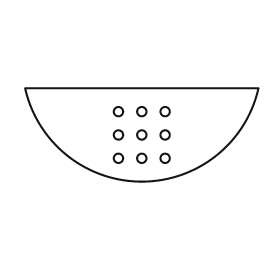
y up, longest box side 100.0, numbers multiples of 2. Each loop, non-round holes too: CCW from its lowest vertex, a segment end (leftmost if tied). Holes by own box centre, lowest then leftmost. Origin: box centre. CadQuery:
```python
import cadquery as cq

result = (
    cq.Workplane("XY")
    .moveTo(-50.0, 20.0)
    .threePointArc((0.0, -20.0), (50.0, 20.0))
    .close()
    .moveTo(-10.0, -10.0)
    .circle(2.0)
    .moveTo(0.0, -10.0)
    .circle(2.0)
    .moveTo(10.0, -10.0)
    .circle(2.0)
    .moveTo(-10.0, 0.0)
    .circle(2.0)
    .moveTo(0.0, 0.0)
    .circle(2.0)
    .moveTo(10.0, 0.0)
    .circle(2.0)
    .moveTo(-10.0, 10.0)
    .circle(2.0)
    .moveTo(0.0, 10.0)
    .circle(2.0)
    .moveTo(10.0, 10.0)
    .circle(2.0)
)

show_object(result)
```